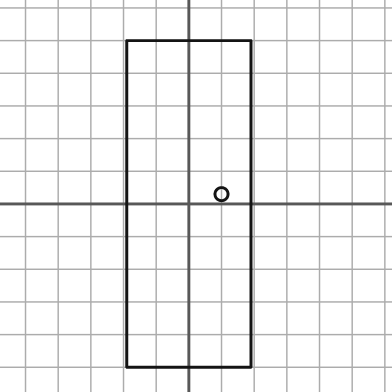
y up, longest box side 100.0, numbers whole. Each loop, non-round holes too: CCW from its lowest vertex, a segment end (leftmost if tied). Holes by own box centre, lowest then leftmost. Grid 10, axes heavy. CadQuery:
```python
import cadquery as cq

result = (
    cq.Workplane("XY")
    .moveTo(-19.0, -50.0)
    .lineTo(19.0, -50.0)
    .lineTo(19.0, 50.0)
    .lineTo(-19.0, 50.0)
    .close()
    .moveTo(10.0, 3.0)
    .circle(2.0)
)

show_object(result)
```